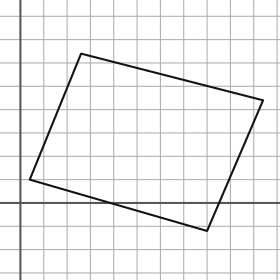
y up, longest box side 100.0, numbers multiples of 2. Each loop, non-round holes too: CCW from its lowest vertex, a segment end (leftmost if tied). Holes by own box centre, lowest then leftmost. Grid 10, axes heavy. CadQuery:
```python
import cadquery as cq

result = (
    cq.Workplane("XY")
    .moveTo(80.0, -12.0)
    .lineTo(104.0, 44.0)
    .lineTo(26.0, 64.0)
    .lineTo(4.0, 10.0)
    .close()
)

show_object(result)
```